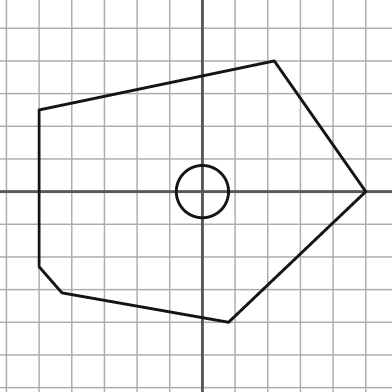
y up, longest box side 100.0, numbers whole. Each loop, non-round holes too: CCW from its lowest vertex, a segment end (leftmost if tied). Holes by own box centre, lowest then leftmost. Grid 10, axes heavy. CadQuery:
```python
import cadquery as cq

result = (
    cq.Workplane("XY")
    .moveTo(8.0, -40.0)
    .lineTo(50.0, 0.0)
    .lineTo(22.0, 40.0)
    .lineTo(-50.0, 25.0)
    .lineTo(-50.0, -23.0)
    .lineTo(-43.0, -31.0)
    .close()
    .moveTo(0.0, 0.0)
    .circle(8.0)
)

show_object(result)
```